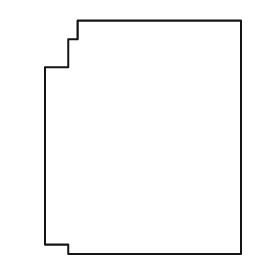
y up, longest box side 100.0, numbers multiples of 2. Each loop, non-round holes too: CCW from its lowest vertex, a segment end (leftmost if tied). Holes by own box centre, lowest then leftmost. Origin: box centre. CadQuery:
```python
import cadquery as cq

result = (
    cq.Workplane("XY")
    .moveTo(-32.0, -50.0)
    .lineTo(42.0, -50.0)
    .lineTo(42.0, 50.0)
    .lineTo(-28.0, 50.0)
    .lineTo(-28.0, 42.0)
    .lineTo(-32.0, 42.0)
    .lineTo(-32.0, 30.0)
    .lineTo(-42.0, 30.0)
    .lineTo(-42.0, -46.0)
    .lineTo(-32.0, -46.0)
    .close()
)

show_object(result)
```